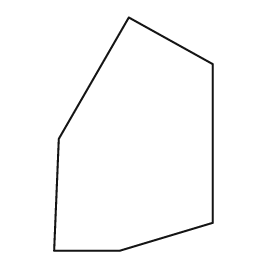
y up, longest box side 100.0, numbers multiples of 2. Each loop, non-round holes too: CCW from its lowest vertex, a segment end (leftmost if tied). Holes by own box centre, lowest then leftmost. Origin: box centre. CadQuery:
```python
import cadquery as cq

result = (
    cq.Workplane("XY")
    .moveTo(-34.0, -50.0)
    .lineTo(-6.0, -50.0)
    .lineTo(34.0, -38.0)
    .lineTo(34.0, 30.0)
    .lineTo(-2.0, 50.0)
    .lineTo(-32.0, -2.0)
    .close()
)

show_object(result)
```